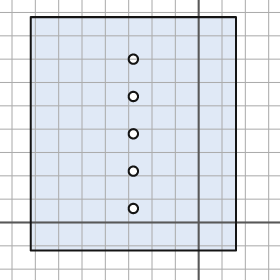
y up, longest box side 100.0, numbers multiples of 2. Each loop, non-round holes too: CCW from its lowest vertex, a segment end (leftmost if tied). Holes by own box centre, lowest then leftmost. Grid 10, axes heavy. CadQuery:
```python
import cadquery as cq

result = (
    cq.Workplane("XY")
    .moveTo(-72.0, -12.0)
    .lineTo(16.0, -12.0)
    .lineTo(16.0, 88.0)
    .lineTo(-72.0, 88.0)
    .close()
    .moveTo(-28.0, 6.0)
    .circle(2.0)
    .moveTo(-28.0, 22.0)
    .circle(2.0)
    .moveTo(-28.0, 38.0)
    .circle(2.0)
    .moveTo(-28.0, 54.0)
    .circle(2.0)
    .moveTo(-28.0, 70.0)
    .circle(2.0)
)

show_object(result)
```